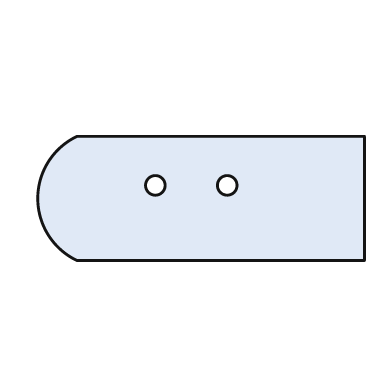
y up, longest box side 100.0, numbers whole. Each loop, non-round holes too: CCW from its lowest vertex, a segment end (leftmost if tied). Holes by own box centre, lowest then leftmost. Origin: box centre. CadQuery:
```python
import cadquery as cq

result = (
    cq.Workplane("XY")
    .moveTo(-38.0, -19.0)
    .lineTo(50.0, -19.0)
    .lineTo(50.0, 19.0)
    .lineTo(-38.0, 19.0)
    .threePointArc((-50.0, 0.0), (-38.0, -19.0))
    .close()
    .moveTo(-14.0, 4.0)
    .circle(3.0)
    .moveTo(8.0, 4.0)
    .circle(3.0)
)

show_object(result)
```